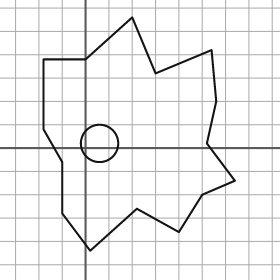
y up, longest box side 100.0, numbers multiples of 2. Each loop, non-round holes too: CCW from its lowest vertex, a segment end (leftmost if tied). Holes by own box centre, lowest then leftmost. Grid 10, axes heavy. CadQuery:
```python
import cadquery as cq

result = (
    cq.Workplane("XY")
    .moveTo(2.0, -44.0)
    .lineTo(22.0, -26.0)
    .lineTo(40.0, -36.0)
    .lineTo(50.0, -20.0)
    .lineTo(64.0, -14.0)
    .lineTo(52.0, 2.0)
    .lineTo(56.0, 20.0)
    .lineTo(54.0, 42.0)
    .lineTo(30.0, 32.0)
    .lineTo(20.0, 56.0)
    .lineTo(0.0, 38.0)
    .lineTo(-18.0, 38.0)
    .lineTo(-18.0, 8.0)
    .lineTo(-10.0, -6.0)
    .lineTo(-10.0, -28.0)
    .close()
    .moveTo(6.0, 2.0)
    .circle(8.0)
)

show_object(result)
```